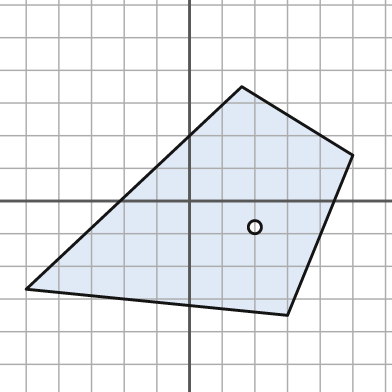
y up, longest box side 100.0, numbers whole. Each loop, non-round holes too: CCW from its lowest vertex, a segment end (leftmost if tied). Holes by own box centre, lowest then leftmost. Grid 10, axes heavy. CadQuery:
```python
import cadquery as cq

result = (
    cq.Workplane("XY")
    .moveTo(30.0, -35.0)
    .lineTo(50.0, 14.0)
    .lineTo(16.0, 35.0)
    .lineTo(-50.0, -27.0)
    .close()
    .moveTo(20.0, -8.0)
    .circle(2.0)
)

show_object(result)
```